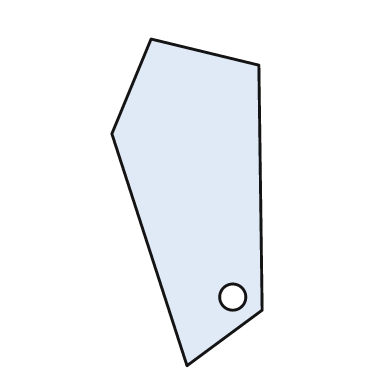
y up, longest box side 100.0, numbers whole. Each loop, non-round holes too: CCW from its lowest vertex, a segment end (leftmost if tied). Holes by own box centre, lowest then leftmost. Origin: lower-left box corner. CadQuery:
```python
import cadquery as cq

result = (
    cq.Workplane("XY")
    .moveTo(23.0, 0.0)
    .lineTo(46.0, 17.0)
    .lineTo(45.0, 92.0)
    .lineTo(12.0, 100.0)
    .lineTo(0.0, 71.0)
    .close()
    .moveTo(37.0, 21.0)
    .circle(4.0)
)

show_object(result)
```